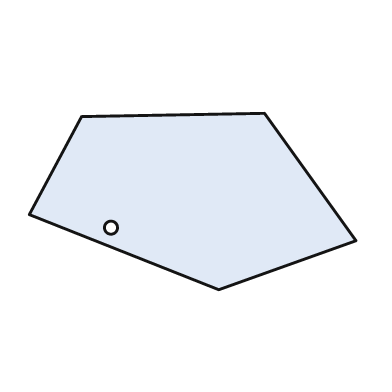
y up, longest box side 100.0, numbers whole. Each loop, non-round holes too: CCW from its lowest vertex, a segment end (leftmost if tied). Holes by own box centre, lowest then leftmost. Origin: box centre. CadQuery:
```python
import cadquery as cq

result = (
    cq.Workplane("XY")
    .moveTo(8.0, -27.0)
    .lineTo(50.0, -12.0)
    .lineTo(22.0, 27.0)
    .lineTo(-34.0, 26.0)
    .lineTo(-50.0, -4.0)
    .close()
    .moveTo(-25.0, -8.0)
    .circle(2.0)
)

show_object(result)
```